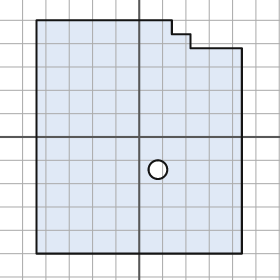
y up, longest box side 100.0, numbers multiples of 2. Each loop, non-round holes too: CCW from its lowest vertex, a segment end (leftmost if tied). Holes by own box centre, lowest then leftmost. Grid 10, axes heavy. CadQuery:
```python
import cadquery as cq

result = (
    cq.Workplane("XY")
    .moveTo(-44.0, -50.0)
    .lineTo(44.0, -50.0)
    .lineTo(44.0, 38.0)
    .lineTo(22.0, 38.0)
    .lineTo(22.0, 44.0)
    .lineTo(14.0, 44.0)
    .lineTo(14.0, 50.0)
    .lineTo(-44.0, 50.0)
    .close()
    .moveTo(8.0, -14.0)
    .circle(4.0)
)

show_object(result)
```